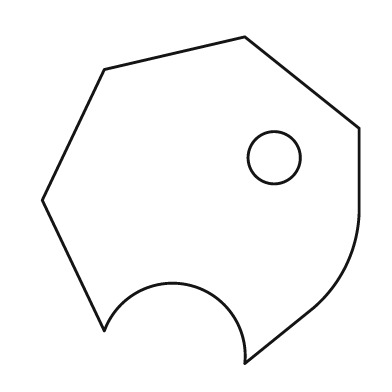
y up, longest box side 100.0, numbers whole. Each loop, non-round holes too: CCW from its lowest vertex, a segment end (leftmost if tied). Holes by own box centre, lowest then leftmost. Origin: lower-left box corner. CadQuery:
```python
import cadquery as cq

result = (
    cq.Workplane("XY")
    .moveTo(62.0, 0.0)
    .lineTo(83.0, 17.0)
    .threePointArc((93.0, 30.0), (97.0, 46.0))
    .lineTo(97.0, 72.0)
    .lineTo(62.0, 100.0)
    .lineTo(19.0, 90.0)
    .lineTo(0.0, 50.0)
    .lineTo(19.0, 10.0)
    .threePointArc((45.0, 24.0), (62.0, 0.0))
    .close()
    .moveTo(71.0, 63.0)
    .circle(8.0)
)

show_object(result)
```